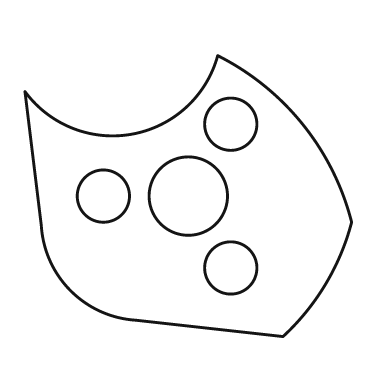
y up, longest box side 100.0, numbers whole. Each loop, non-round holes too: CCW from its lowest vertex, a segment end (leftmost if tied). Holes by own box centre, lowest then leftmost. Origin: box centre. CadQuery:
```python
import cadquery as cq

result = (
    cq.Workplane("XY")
    .moveTo(29.0, -43.0)
    .threePointArc((42.0, -27.0), (50.0, -8.0))
    .threePointArc((35.0, 22.0), (9.0, 43.0))
    .threePointArc((-17.0, 19.0), (-50.0, 32.0))
    .lineTo(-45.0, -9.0)
    .threePointArc((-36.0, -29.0), (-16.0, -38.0))
    .close()
    .moveTo(13.0, -22.0)
    .circle(8.0)
    .moveTo(-26.0, 0.0)
    .circle(8.0)
    .moveTo(0.0, 0.0)
    .circle(12.0)
    .moveTo(13.0, 22.0)
    .circle(8.0)
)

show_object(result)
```